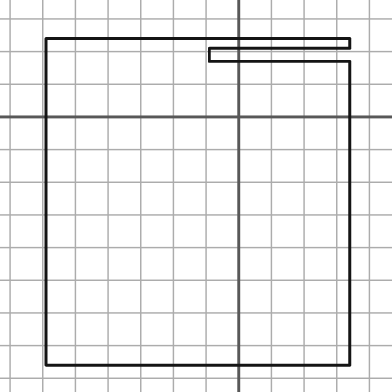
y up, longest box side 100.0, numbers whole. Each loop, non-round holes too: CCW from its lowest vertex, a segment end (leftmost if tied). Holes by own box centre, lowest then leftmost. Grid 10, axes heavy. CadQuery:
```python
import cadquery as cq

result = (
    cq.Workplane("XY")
    .moveTo(-59.0, -76.0)
    .lineTo(34.0, -76.0)
    .lineTo(34.0, 17.0)
    .lineTo(-9.0, 17.0)
    .lineTo(-9.0, 21.0)
    .lineTo(34.0, 21.0)
    .lineTo(34.0, 24.0)
    .lineTo(-59.0, 24.0)
    .close()
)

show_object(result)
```